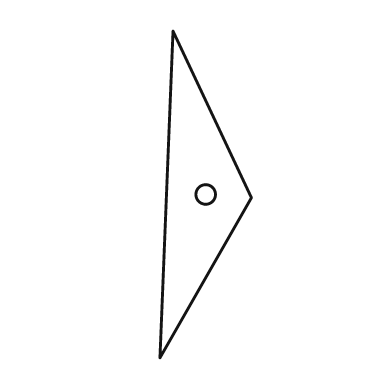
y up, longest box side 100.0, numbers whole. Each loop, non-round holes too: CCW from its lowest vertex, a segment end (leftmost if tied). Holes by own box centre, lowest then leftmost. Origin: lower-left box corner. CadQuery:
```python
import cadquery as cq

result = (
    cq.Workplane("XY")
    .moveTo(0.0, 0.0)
    .lineTo(28.0, 49.0)
    .lineTo(4.0, 100.0)
    .close()
    .moveTo(14.0, 50.0)
    .circle(3.0)
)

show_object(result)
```